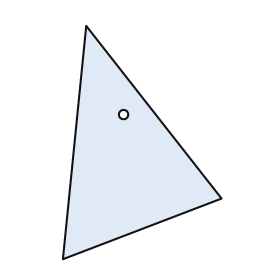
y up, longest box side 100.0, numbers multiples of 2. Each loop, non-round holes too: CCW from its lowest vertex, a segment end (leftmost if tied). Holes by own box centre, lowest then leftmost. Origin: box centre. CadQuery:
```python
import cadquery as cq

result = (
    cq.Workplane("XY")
    .moveTo(-34.0, -50.0)
    .lineTo(34.0, -24.0)
    .lineTo(-24.0, 50.0)
    .close()
    .moveTo(-8.0, 12.0)
    .circle(2.0)
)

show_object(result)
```